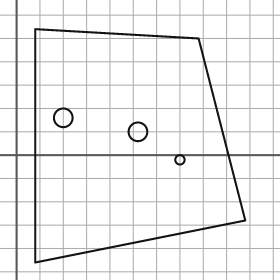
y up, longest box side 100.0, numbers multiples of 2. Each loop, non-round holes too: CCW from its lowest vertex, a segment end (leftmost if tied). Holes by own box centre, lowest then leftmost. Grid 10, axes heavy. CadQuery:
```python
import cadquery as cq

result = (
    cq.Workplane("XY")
    .moveTo(8.0, -46.0)
    .lineTo(98.0, -28.0)
    .lineTo(78.0, 50.0)
    .lineTo(8.0, 54.0)
    .close()
    .moveTo(70.0, -2.0)
    .circle(2.0)
    .moveTo(52.0, 10.0)
    .circle(4.0)
    .moveTo(20.0, 16.0)
    .circle(4.0)
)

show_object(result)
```